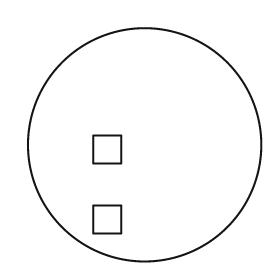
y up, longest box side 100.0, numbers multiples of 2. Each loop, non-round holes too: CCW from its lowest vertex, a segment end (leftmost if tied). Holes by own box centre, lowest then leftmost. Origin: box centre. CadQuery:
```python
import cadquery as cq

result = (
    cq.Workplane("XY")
    .moveTo(0.0, 0.0)
    .circle(50.0)
    .moveTo(-22.0, -38.0)
    .lineTo(-10.0, -38.0)
    .lineTo(-10.0, -26.0)
    .lineTo(-22.0, -26.0)
    .close()
    .moveTo(-22.0, -8.0)
    .lineTo(-10.0, -8.0)
    .lineTo(-10.0, 4.0)
    .lineTo(-22.0, 4.0)
    .close()
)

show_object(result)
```